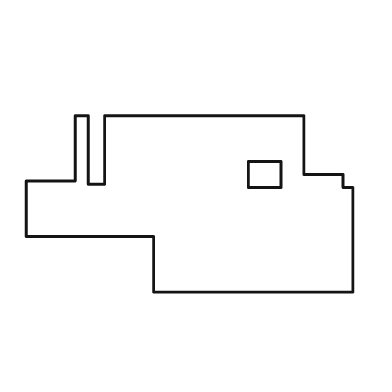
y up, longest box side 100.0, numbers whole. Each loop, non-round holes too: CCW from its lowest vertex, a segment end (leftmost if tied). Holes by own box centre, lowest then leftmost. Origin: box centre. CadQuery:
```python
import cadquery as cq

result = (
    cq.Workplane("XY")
    .moveTo(-11.0, -27.0)
    .lineTo(50.0, -27.0)
    .lineTo(50.0, 5.0)
    .lineTo(47.0, 5.0)
    .lineTo(47.0, 9.0)
    .lineTo(35.0, 9.0)
    .lineTo(35.0, 27.0)
    .lineTo(-26.0, 27.0)
    .lineTo(-26.0, 6.0)
    .lineTo(-31.0, 6.0)
    .lineTo(-31.0, 27.0)
    .lineTo(-35.0, 27.0)
    .lineTo(-35.0, 7.0)
    .lineTo(-50.0, 7.0)
    .lineTo(-50.0, -10.0)
    .lineTo(-11.0, -10.0)
    .close()
    .moveTo(18.0, 5.0)
    .lineTo(28.0, 5.0)
    .lineTo(28.0, 13.0)
    .lineTo(18.0, 13.0)
    .close()
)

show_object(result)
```